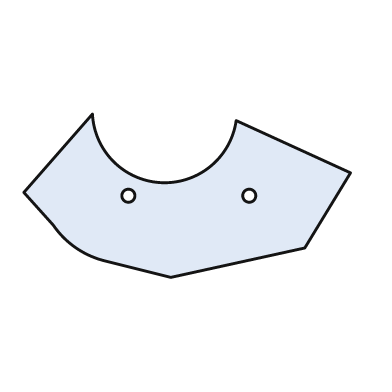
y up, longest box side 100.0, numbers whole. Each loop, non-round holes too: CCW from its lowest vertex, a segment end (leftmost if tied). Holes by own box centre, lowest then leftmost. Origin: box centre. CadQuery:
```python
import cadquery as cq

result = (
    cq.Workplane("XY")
    .moveTo(-5.0, -25.0)
    .lineTo(36.0, -16.0)
    .lineTo(50.0, 7.0)
    .lineTo(15.0, 23.0)
    .threePointArc((-8.0, 4.0), (-29.0, 25.0))
    .lineTo(-50.0, 1.0)
    .lineTo(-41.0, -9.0)
    .threePointArc((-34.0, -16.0), (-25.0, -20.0))
    .close()
    .moveTo(-18.0, 0.0)
    .circle(2.0)
    .moveTo(19.0, 0.0)
    .circle(2.0)
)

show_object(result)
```